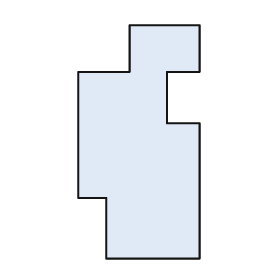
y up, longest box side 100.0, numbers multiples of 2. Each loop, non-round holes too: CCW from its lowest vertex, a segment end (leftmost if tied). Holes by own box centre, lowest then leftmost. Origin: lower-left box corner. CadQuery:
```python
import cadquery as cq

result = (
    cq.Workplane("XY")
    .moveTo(12.0, 0.0)
    .lineTo(52.0, 0.0)
    .lineTo(52.0, 58.0)
    .lineTo(38.0, 58.0)
    .lineTo(38.0, 80.0)
    .lineTo(52.0, 80.0)
    .lineTo(52.0, 100.0)
    .lineTo(22.0, 100.0)
    .lineTo(22.0, 80.0)
    .lineTo(0.0, 80.0)
    .lineTo(0.0, 26.0)
    .lineTo(12.0, 26.0)
    .close()
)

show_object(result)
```